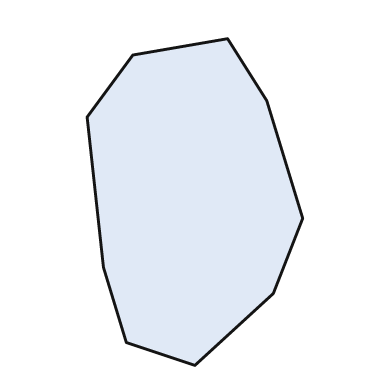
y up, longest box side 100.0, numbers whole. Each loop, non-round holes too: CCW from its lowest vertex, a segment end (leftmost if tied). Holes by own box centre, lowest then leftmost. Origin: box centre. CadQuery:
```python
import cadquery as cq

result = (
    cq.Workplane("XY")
    .moveTo(0.0, -50.0)
    .lineTo(24.0, -28.0)
    .lineTo(33.0, -5.0)
    .lineTo(22.0, 31.0)
    .lineTo(10.0, 50.0)
    .lineTo(-19.0, 45.0)
    .lineTo(-33.0, 26.0)
    .lineTo(-28.0, -20.0)
    .lineTo(-21.0, -43.0)
    .close()
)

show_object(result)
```